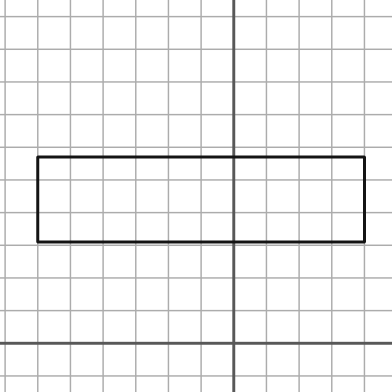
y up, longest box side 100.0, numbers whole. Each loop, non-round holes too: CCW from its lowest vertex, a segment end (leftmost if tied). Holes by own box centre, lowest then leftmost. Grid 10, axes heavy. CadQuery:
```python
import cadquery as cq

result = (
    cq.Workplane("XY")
    .moveTo(-60.0, 31.0)
    .lineTo(40.0, 31.0)
    .lineTo(40.0, 57.0)
    .lineTo(-60.0, 57.0)
    .close()
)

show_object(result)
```